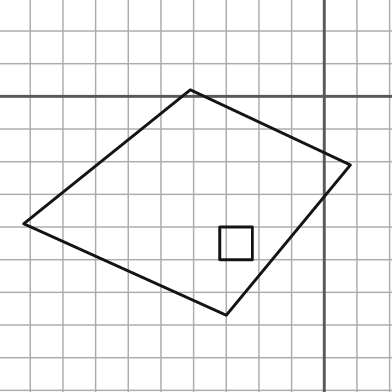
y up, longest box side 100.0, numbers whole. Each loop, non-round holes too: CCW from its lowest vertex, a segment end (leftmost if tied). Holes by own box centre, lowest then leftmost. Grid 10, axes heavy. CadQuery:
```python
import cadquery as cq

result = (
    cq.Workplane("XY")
    .moveTo(-30.0, -67.0)
    .lineTo(8.0, -21.0)
    .lineTo(-41.0, 2.0)
    .lineTo(-92.0, -39.0)
    .close()
    .moveTo(-32.0, -50.0)
    .lineTo(-22.0, -50.0)
    .lineTo(-22.0, -40.0)
    .lineTo(-32.0, -40.0)
    .close()
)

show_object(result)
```